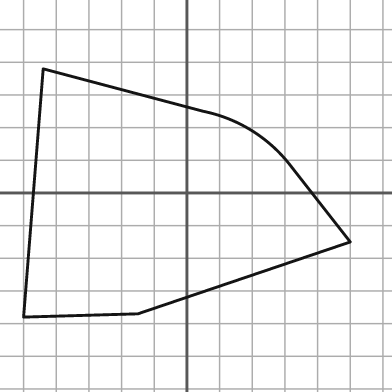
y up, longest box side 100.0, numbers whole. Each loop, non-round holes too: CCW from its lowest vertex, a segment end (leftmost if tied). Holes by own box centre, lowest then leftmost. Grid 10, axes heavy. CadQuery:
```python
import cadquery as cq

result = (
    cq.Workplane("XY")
    .moveTo(-50.0, -38.0)
    .lineTo(-15.0, -37.0)
    .lineTo(50.0, -15.0)
    .lineTo(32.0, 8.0)
    .threePointArc((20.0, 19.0), (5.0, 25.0))
    .lineTo(-44.0, 38.0)
    .close()
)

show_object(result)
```